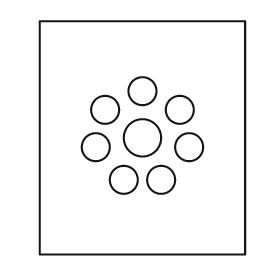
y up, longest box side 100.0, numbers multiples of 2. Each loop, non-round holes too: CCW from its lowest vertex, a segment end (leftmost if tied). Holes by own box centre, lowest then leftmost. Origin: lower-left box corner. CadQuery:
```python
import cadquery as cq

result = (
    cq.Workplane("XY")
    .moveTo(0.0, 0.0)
    .lineTo(88.0, 0.0)
    .lineTo(88.0, 100.0)
    .lineTo(0.0, 100.0)
    .close()
    .moveTo(36.0, 32.0)
    .circle(6.0)
    .moveTo(52.0, 32.0)
    .circle(6.0)
    .moveTo(24.0, 46.0)
    .circle(6.0)
    .moveTo(64.0, 46.0)
    .circle(6.0)
    .moveTo(44.0, 50.0)
    .circle(8.0)
    .moveTo(28.0, 62.0)
    .circle(6.0)
    .moveTo(60.0, 62.0)
    .circle(6.0)
    .moveTo(44.0, 70.0)
    .circle(6.0)
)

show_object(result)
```